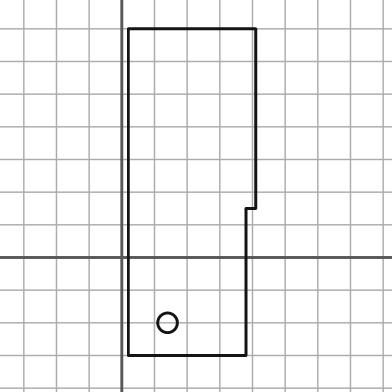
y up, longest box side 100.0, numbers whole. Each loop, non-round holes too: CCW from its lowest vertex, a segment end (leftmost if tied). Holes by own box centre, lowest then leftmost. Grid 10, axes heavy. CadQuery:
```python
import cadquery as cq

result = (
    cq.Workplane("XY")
    .moveTo(2.0, -30.0)
    .lineTo(38.0, -30.0)
    .lineTo(38.0, 15.0)
    .lineTo(41.0, 15.0)
    .lineTo(41.0, 70.0)
    .lineTo(2.0, 70.0)
    .close()
    .moveTo(14.0, -20.0)
    .circle(3.0)
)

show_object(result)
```